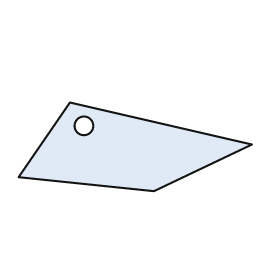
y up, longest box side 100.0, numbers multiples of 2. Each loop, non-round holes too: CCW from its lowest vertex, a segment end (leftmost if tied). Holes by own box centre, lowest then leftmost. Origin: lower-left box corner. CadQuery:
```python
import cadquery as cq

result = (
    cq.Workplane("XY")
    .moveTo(58.0, 0.0)
    .lineTo(100.0, 20.0)
    .lineTo(22.0, 38.0)
    .lineTo(0.0, 6.0)
    .close()
    .moveTo(28.0, 28.0)
    .circle(4.0)
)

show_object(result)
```